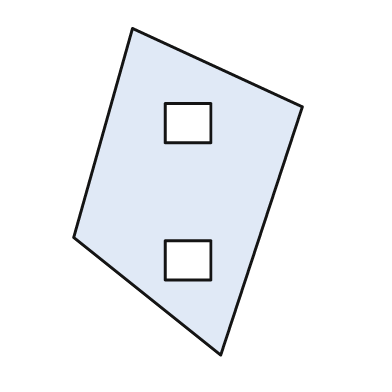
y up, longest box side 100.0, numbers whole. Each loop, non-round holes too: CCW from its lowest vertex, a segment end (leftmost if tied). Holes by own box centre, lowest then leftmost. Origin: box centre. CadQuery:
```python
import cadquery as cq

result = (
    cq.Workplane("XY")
    .moveTo(10.0, -50.0)
    .lineTo(35.0, 26.0)
    .lineTo(-17.0, 50.0)
    .lineTo(-35.0, -14.0)
    .close()
    .moveTo(-7.0, -27.0)
    .lineTo(7.0, -27.0)
    .lineTo(7.0, -15.0)
    .lineTo(-7.0, -15.0)
    .close()
    .moveTo(-7.0, 15.0)
    .lineTo(7.0, 15.0)
    .lineTo(7.0, 27.0)
    .lineTo(-7.0, 27.0)
    .close()
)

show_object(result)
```